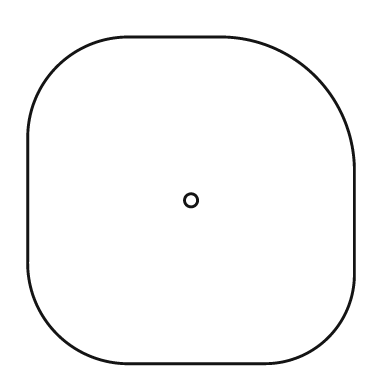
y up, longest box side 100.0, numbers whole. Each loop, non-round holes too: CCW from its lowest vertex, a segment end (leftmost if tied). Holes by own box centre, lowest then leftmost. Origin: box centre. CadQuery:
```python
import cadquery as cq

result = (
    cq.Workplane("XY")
    .moveTo(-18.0, -50.0)
    .lineTo(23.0, -50.0)
    .threePointArc((42.0, -42.0), (50.0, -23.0))
    .lineTo(50.0, 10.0)
    .threePointArc((38.0, 38.0), (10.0, 50.0))
    .lineTo(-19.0, 50.0)
    .threePointArc((-41.0, 41.0), (-50.0, 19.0))
    .lineTo(-50.0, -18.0)
    .threePointArc((-41.0, -41.0), (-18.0, -50.0))
    .close()
    .moveTo(0.0, 0.0)
    .circle(2.0)
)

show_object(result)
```